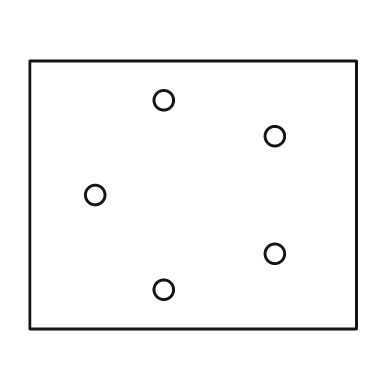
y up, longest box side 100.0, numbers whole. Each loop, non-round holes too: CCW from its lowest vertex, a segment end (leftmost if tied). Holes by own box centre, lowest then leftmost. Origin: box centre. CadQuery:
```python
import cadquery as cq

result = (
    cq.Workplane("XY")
    .moveTo(-50.0, -41.0)
    .lineTo(50.0, -41.0)
    .lineTo(50.0, 41.0)
    .lineTo(-50.0, 41.0)
    .close()
    .moveTo(-9.0, -29.0)
    .circle(3.0)
    .moveTo(25.0, -18.0)
    .circle(3.0)
    .moveTo(-30.0, 0.0)
    .circle(3.0)
    .moveTo(25.0, 18.0)
    .circle(3.0)
    .moveTo(-9.0, 29.0)
    .circle(3.0)
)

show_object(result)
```